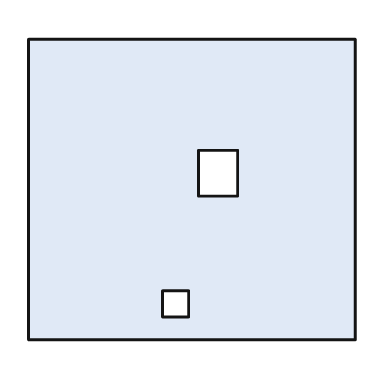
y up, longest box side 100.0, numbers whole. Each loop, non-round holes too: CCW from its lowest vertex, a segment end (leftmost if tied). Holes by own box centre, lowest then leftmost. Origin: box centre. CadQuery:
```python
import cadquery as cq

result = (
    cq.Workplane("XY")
    .moveTo(-50.0, -46.0)
    .lineTo(50.0, -46.0)
    .lineTo(50.0, 46.0)
    .lineTo(-50.0, 46.0)
    .close()
    .moveTo(-9.0, -39.0)
    .lineTo(-1.0, -39.0)
    .lineTo(-1.0, -31.0)
    .lineTo(-9.0, -31.0)
    .close()
    .moveTo(2.0, -2.0)
    .lineTo(14.0, -2.0)
    .lineTo(14.0, 12.0)
    .lineTo(2.0, 12.0)
    .close()
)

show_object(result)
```